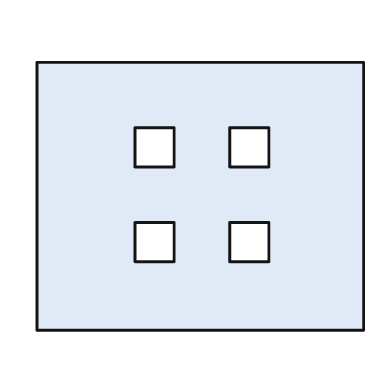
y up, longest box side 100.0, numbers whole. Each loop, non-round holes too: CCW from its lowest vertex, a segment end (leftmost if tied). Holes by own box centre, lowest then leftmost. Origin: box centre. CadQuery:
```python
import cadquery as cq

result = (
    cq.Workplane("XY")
    .moveTo(-50.0, -41.0)
    .lineTo(50.0, -41.0)
    .lineTo(50.0, 41.0)
    .lineTo(-50.0, 41.0)
    .close()
    .moveTo(-20.0, -20.0)
    .lineTo(-8.0, -20.0)
    .lineTo(-8.0, -8.0)
    .lineTo(-20.0, -8.0)
    .close()
    .moveTo(9.0, -20.0)
    .lineTo(21.0, -20.0)
    .lineTo(21.0, -8.0)
    .lineTo(9.0, -8.0)
    .close()
    .moveTo(-20.0, 9.0)
    .lineTo(-8.0, 9.0)
    .lineTo(-8.0, 21.0)
    .lineTo(-20.0, 21.0)
    .close()
    .moveTo(9.0, 9.0)
    .lineTo(21.0, 9.0)
    .lineTo(21.0, 21.0)
    .lineTo(9.0, 21.0)
    .close()
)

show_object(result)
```